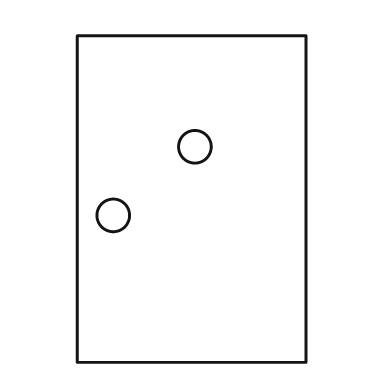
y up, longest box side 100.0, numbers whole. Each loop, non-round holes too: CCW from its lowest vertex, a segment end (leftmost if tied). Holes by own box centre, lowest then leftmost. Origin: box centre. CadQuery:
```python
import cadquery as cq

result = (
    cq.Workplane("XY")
    .moveTo(-35.0, -50.0)
    .lineTo(35.0, -50.0)
    .lineTo(35.0, 50.0)
    .lineTo(-35.0, 50.0)
    .close()
    .moveTo(-24.0, -5.0)
    .circle(5.0)
    .moveTo(1.0, 16.0)
    .circle(5.0)
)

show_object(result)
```